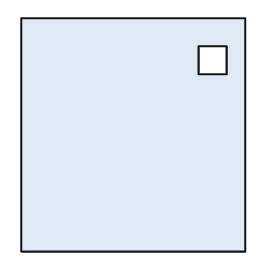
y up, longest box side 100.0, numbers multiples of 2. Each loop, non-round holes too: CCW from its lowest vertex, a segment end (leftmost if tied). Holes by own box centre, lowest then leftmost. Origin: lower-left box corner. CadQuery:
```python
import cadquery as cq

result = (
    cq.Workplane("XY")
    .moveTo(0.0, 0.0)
    .lineTo(96.0, 0.0)
    .lineTo(96.0, 100.0)
    .lineTo(0.0, 100.0)
    .close()
    .moveTo(76.0, 76.0)
    .lineTo(88.0, 76.0)
    .lineTo(88.0, 88.0)
    .lineTo(76.0, 88.0)
    .close()
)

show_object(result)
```